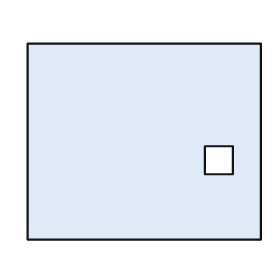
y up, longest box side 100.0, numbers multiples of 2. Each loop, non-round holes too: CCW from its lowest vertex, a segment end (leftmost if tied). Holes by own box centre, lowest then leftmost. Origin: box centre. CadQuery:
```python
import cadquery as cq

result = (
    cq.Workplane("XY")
    .moveTo(-50.0, -42.0)
    .lineTo(50.0, -42.0)
    .lineTo(50.0, 42.0)
    .lineTo(-50.0, 42.0)
    .close()
    .moveTo(26.0, -14.0)
    .lineTo(38.0, -14.0)
    .lineTo(38.0, -2.0)
    .lineTo(26.0, -2.0)
    .close()
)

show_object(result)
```